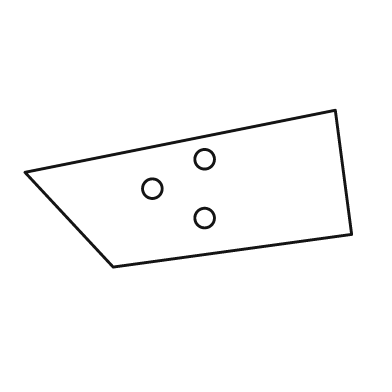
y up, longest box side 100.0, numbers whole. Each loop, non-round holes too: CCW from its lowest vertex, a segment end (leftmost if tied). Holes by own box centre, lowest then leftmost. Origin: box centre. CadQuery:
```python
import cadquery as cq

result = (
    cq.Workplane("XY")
    .moveTo(-23.0, -24.0)
    .lineTo(50.0, -14.0)
    .lineTo(45.0, 24.0)
    .lineTo(-50.0, 5.0)
    .close()
    .moveTo(5.0, -9.0)
    .circle(3.0)
    .moveTo(-11.0, 0.0)
    .circle(3.0)
    .moveTo(5.0, 9.0)
    .circle(3.0)
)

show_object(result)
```